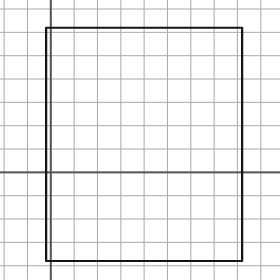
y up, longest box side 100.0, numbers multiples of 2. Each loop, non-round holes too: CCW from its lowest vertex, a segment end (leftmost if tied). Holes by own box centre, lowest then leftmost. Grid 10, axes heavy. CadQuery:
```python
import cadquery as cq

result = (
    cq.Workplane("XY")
    .moveTo(-2.0, -38.0)
    .lineTo(82.0, -38.0)
    .lineTo(82.0, 62.0)
    .lineTo(-2.0, 62.0)
    .close()
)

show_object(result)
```